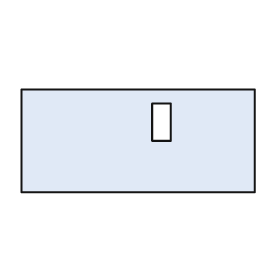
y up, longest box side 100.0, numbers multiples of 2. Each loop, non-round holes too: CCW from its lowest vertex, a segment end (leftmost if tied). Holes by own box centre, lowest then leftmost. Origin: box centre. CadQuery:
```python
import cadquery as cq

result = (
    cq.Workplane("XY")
    .moveTo(-50.0, -22.0)
    .lineTo(50.0, -22.0)
    .lineTo(50.0, 22.0)
    .lineTo(-50.0, 22.0)
    .close()
    .moveTo(6.0, 0.0)
    .lineTo(14.0, 0.0)
    .lineTo(14.0, 16.0)
    .lineTo(6.0, 16.0)
    .close()
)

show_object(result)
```